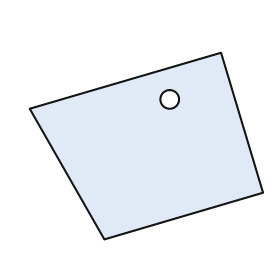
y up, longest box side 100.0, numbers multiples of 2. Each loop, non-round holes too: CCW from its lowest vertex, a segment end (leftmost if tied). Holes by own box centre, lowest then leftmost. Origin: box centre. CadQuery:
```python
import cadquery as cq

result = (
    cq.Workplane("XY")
    .moveTo(-18.0, -40.0)
    .lineTo(50.0, -20.0)
    .lineTo(32.0, 40.0)
    .lineTo(-50.0, 16.0)
    .close()
    .moveTo(10.0, 20.0)
    .circle(4.0)
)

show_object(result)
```